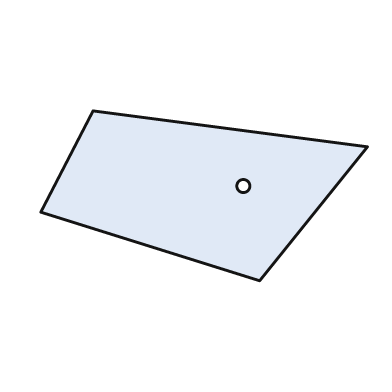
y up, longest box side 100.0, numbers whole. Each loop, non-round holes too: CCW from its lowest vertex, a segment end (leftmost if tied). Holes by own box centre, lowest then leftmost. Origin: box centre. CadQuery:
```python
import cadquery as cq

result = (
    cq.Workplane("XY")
    .moveTo(17.0, -26.0)
    .lineTo(50.0, 15.0)
    .lineTo(-34.0, 26.0)
    .lineTo(-50.0, -5.0)
    .close()
    .moveTo(12.0, 3.0)
    .circle(2.0)
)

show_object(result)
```